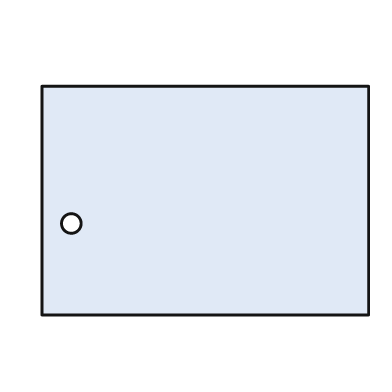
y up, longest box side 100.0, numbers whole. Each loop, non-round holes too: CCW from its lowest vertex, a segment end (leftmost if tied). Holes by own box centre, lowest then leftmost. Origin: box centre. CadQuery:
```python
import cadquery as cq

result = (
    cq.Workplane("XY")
    .moveTo(-50.0, -35.0)
    .lineTo(50.0, -35.0)
    .lineTo(50.0, 35.0)
    .lineTo(-50.0, 35.0)
    .close()
    .moveTo(-41.0, -7.0)
    .circle(3.0)
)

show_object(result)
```